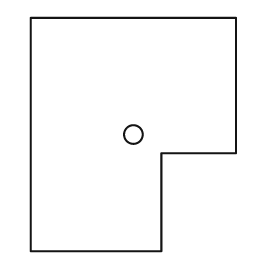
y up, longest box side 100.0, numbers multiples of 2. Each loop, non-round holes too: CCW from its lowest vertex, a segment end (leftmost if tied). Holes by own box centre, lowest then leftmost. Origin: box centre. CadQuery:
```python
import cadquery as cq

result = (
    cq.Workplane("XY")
    .moveTo(-44.0, -50.0)
    .lineTo(12.0, -50.0)
    .lineTo(12.0, -8.0)
    .lineTo(44.0, -8.0)
    .lineTo(44.0, 50.0)
    .lineTo(-44.0, 50.0)
    .close()
    .moveTo(0.0, 0.0)
    .circle(4.0)
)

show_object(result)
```